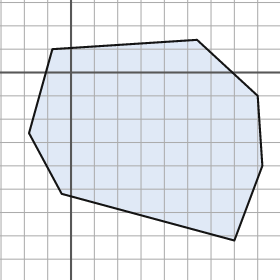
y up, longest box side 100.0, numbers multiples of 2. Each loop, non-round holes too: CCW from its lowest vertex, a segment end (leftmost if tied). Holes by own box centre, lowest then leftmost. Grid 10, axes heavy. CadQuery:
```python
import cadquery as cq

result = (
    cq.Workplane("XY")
    .moveTo(70.0, -72.0)
    .lineTo(82.0, -40.0)
    .lineTo(80.0, -10.0)
    .lineTo(54.0, 14.0)
    .lineTo(-8.0, 10.0)
    .lineTo(-18.0, -26.0)
    .lineTo(-4.0, -52.0)
    .close()
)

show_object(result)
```